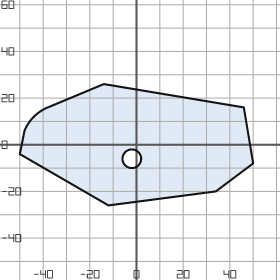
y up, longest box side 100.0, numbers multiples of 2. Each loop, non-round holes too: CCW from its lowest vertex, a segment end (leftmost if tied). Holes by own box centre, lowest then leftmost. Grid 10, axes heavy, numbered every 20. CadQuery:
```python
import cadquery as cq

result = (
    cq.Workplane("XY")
    .moveTo(-12.0, -26.0)
    .lineTo(34.0, -20.0)
    .lineTo(50.0, -8.0)
    .lineTo(46.0, 16.0)
    .lineTo(-14.0, 26.0)
    .lineTo(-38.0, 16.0)
    .threePointArc((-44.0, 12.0), (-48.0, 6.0))
    .lineTo(-50.0, -4.0)
    .close()
    .moveTo(-2.0, -6.0)
    .circle(4.0)
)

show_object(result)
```